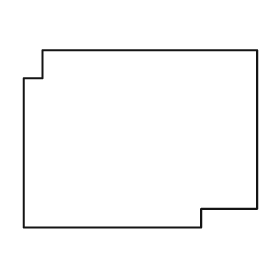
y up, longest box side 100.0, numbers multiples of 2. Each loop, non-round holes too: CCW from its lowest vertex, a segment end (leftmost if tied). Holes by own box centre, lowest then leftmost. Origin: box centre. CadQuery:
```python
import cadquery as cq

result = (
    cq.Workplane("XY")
    .moveTo(-50.0, -38.0)
    .lineTo(26.0, -38.0)
    .lineTo(26.0, -30.0)
    .lineTo(50.0, -30.0)
    .lineTo(50.0, 38.0)
    .lineTo(-42.0, 38.0)
    .lineTo(-42.0, 26.0)
    .lineTo(-50.0, 26.0)
    .close()
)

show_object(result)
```